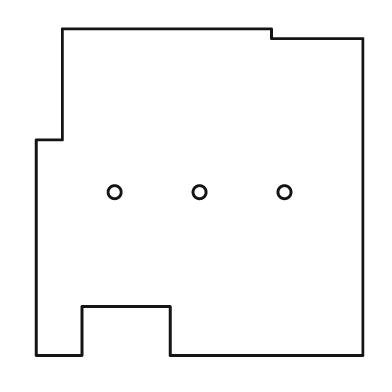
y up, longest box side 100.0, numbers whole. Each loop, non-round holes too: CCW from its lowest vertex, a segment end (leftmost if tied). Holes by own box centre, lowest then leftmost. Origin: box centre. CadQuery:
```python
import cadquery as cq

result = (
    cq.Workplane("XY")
    .moveTo(-50.0, -50.0)
    .lineTo(-36.0, -50.0)
    .lineTo(-36.0, -35.0)
    .lineTo(-9.0, -35.0)
    .lineTo(-9.0, -50.0)
    .lineTo(50.0, -50.0)
    .lineTo(50.0, 47.0)
    .lineTo(22.0, 47.0)
    .lineTo(22.0, 50.0)
    .lineTo(-42.0, 50.0)
    .lineTo(-42.0, 16.0)
    .lineTo(-50.0, 16.0)
    .close()
    .moveTo(-26.0, 0.0)
    .circle(2.0)
    .moveTo(0.0, 0.0)
    .circle(2.0)
    .moveTo(26.0, 0.0)
    .circle(2.0)
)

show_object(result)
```